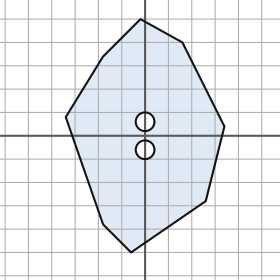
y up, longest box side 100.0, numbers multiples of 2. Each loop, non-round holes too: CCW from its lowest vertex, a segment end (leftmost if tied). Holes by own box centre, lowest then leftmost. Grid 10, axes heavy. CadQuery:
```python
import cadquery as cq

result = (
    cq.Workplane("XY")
    .moveTo(-6.0, -50.0)
    .lineTo(26.0, -28.0)
    .lineTo(34.0, 4.0)
    .lineTo(16.0, 40.0)
    .lineTo(-2.0, 50.0)
    .lineTo(-18.0, 34.0)
    .lineTo(-34.0, 8.0)
    .lineTo(-18.0, -38.0)
    .close()
    .moveTo(0.0, -6.0)
    .circle(4.0)
    .moveTo(0.0, 6.0)
    .circle(4.0)
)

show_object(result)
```